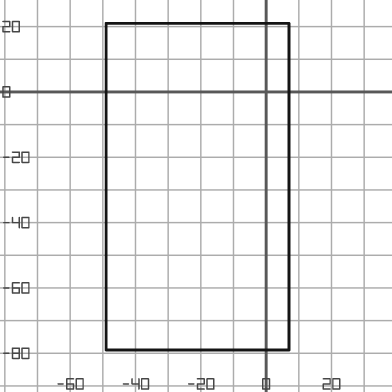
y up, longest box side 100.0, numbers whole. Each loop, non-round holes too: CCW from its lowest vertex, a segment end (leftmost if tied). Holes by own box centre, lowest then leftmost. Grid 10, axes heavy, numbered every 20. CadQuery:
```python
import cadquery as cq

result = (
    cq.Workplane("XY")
    .moveTo(-49.0, -79.0)
    .lineTo(7.0, -79.0)
    .lineTo(7.0, 21.0)
    .lineTo(-49.0, 21.0)
    .close()
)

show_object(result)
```